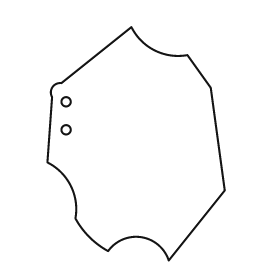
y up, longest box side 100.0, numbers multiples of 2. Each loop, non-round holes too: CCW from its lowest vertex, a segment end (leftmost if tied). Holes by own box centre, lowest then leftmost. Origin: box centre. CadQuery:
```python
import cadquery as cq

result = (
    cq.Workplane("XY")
    .moveTo(14.0, -50.0)
    .lineTo(38.0, -20.0)
    .lineTo(32.0, 24.0)
    .lineTo(22.0, 38.0)
    .threePointArc((8.0, 40.0), (-2.0, 50.0))
    .lineTo(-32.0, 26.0)
    .threePointArc((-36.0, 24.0), (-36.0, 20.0))
    .lineTo(-38.0, -8.0)
    .threePointArc((-28.0, -18.0), (-26.0, -32.0))
    .threePointArc((-20.0, -40.0), (-12.0, -46.0))
    .threePointArc((2.0, -40.0), (14.0, -50.0))
    .close()
    .moveTo(-30.0, 6.0)
    .circle(2.0)
    .moveTo(-30.0, 18.0)
    .circle(2.0)
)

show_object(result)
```